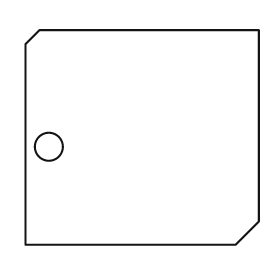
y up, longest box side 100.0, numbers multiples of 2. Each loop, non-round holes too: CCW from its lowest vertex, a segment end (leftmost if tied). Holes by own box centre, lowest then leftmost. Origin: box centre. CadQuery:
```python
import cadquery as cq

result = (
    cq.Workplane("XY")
    .moveTo(-50.0, -46.0)
    .lineTo(40.0, -46.0)
    .lineTo(50.0, -36.0)
    .lineTo(50.0, 46.0)
    .lineTo(-44.0, 46.0)
    .lineTo(-50.0, 40.0)
    .close()
    .moveTo(-40.0, -4.0)
    .circle(6.0)
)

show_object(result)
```